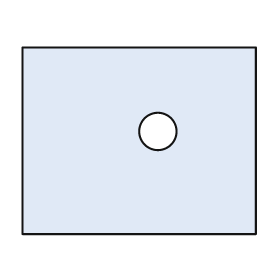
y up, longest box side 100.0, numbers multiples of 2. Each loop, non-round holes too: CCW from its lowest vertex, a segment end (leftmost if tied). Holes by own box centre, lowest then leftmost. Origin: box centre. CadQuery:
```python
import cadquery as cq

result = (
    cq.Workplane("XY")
    .moveTo(-50.0, -40.0)
    .lineTo(50.0, -40.0)
    .lineTo(50.0, 40.0)
    .lineTo(-50.0, 40.0)
    .close()
    .moveTo(8.0, 4.0)
    .circle(8.0)
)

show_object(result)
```